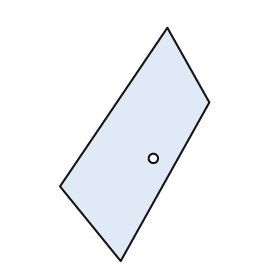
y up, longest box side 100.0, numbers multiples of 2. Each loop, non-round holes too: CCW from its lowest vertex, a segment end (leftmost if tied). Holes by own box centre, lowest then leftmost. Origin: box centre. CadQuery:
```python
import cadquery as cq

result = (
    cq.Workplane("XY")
    .moveTo(-6.0, -50.0)
    .lineTo(32.0, 18.0)
    .lineTo(14.0, 50.0)
    .lineTo(-32.0, -18.0)
    .close()
    .moveTo(8.0, -6.0)
    .circle(2.0)
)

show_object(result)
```